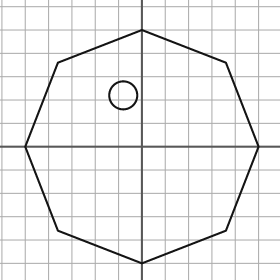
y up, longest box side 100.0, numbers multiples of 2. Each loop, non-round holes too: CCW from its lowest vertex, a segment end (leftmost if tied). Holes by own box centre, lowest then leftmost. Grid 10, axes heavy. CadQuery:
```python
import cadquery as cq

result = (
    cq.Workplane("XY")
    .moveTo(0.0, -50.0)
    .lineTo(36.0, -36.0)
    .lineTo(50.0, 0.0)
    .lineTo(36.0, 36.0)
    .lineTo(0.0, 50.0)
    .lineTo(-36.0, 36.0)
    .lineTo(-50.0, 0.0)
    .lineTo(-36.0, -36.0)
    .close()
    .moveTo(-8.0, 22.0)
    .circle(6.0)
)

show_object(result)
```